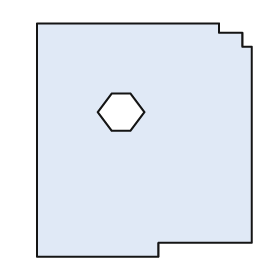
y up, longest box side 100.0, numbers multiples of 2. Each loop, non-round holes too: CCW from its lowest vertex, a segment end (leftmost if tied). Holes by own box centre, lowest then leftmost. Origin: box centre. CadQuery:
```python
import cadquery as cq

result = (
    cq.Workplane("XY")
    .moveTo(-46.0, -50.0)
    .lineTo(6.0, -50.0)
    .lineTo(6.0, -44.0)
    .lineTo(46.0, -44.0)
    .lineTo(46.0, 40.0)
    .lineTo(42.0, 40.0)
    .lineTo(42.0, 46.0)
    .lineTo(32.0, 46.0)
    .lineTo(32.0, 50.0)
    .lineTo(-46.0, 50.0)
    .close()
    .moveTo(-14.0, 4.0)
    .lineTo(-6.0, 4.0)
    .lineTo(0.0, 12.0)
    .lineTo(-6.0, 20.0)
    .lineTo(-14.0, 20.0)
    .lineTo(-20.0, 12.0)
    .close()
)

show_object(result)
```